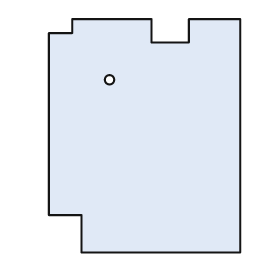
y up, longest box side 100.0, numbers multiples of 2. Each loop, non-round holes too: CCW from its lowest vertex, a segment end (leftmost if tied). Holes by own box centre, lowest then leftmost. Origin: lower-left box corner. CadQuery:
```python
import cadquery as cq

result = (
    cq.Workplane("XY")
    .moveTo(14.0, 0.0)
    .lineTo(82.0, 0.0)
    .lineTo(82.0, 100.0)
    .lineTo(60.0, 100.0)
    .lineTo(60.0, 90.0)
    .lineTo(44.0, 90.0)
    .lineTo(44.0, 100.0)
    .lineTo(10.0, 100.0)
    .lineTo(10.0, 94.0)
    .lineTo(0.0, 94.0)
    .lineTo(0.0, 16.0)
    .lineTo(14.0, 16.0)
    .close()
    .moveTo(26.0, 74.0)
    .circle(2.0)
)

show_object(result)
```